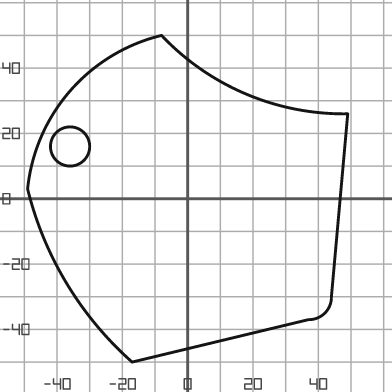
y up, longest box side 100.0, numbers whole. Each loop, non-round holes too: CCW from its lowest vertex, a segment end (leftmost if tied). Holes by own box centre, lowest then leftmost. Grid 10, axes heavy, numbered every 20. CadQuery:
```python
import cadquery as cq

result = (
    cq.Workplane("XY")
    .moveTo(-17.0, -50.0)
    .lineTo(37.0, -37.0)
    .threePointArc((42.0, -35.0), (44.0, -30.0))
    .lineTo(49.0, 26.0)
    .threePointArc((18.0, 32.0), (-8.0, 50.0))
    .threePointArc((-36.0, 33.0), (-49.0, 3.0))
    .threePointArc((-37.0, -26.0), (-17.0, -50.0))
    .close()
    .moveTo(-36.0, 16.0)
    .circle(6.0)
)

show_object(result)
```